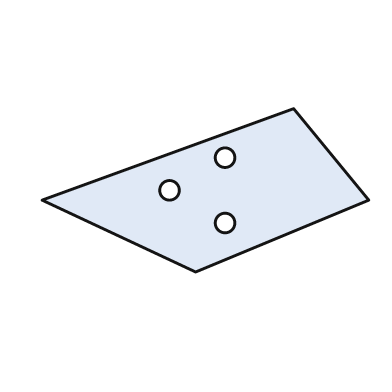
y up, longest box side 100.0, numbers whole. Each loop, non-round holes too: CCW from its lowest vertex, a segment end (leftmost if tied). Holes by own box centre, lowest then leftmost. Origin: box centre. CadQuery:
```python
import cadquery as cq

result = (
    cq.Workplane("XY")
    .moveTo(-3.0, -25.0)
    .lineTo(50.0, -3.0)
    .lineTo(27.0, 25.0)
    .lineTo(-50.0, -3.0)
    .close()
    .moveTo(6.0, -10.0)
    .circle(3.0)
    .moveTo(-11.0, 0.0)
    .circle(3.0)
    .moveTo(6.0, 10.0)
    .circle(3.0)
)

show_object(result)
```